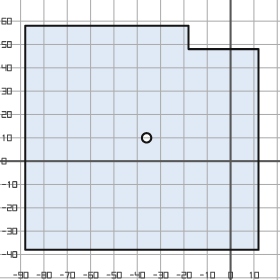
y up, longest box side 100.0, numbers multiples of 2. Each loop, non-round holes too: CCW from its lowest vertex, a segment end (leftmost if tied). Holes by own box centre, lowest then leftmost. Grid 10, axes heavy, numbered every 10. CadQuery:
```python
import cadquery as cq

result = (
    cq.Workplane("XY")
    .moveTo(-88.0, -38.0)
    .lineTo(12.0, -38.0)
    .lineTo(12.0, 48.0)
    .lineTo(-18.0, 48.0)
    .lineTo(-18.0, 58.0)
    .lineTo(-88.0, 58.0)
    .close()
    .moveTo(-36.0, 10.0)
    .circle(2.0)
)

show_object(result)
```